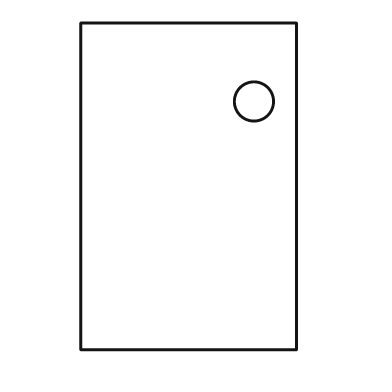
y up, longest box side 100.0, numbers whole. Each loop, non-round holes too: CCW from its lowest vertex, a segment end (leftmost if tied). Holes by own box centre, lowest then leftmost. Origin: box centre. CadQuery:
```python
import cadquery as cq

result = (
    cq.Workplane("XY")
    .moveTo(-33.0, -50.0)
    .lineTo(33.0, -50.0)
    .lineTo(33.0, 50.0)
    .lineTo(-33.0, 50.0)
    .close()
    .moveTo(20.0, 26.0)
    .circle(6.0)
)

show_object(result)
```